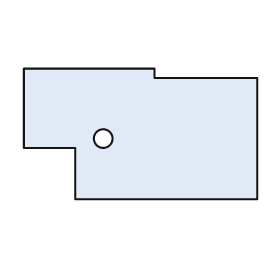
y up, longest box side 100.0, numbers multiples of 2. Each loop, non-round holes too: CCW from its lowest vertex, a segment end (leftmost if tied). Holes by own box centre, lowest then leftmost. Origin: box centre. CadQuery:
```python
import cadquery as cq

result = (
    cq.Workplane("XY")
    .moveTo(-28.0, -28.0)
    .lineTo(50.0, -28.0)
    .lineTo(50.0, 24.0)
    .lineTo(6.0, 24.0)
    .lineTo(6.0, 28.0)
    .lineTo(-50.0, 28.0)
    .lineTo(-50.0, -6.0)
    .lineTo(-28.0, -6.0)
    .close()
    .moveTo(-16.0, -2.0)
    .circle(4.0)
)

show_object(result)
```